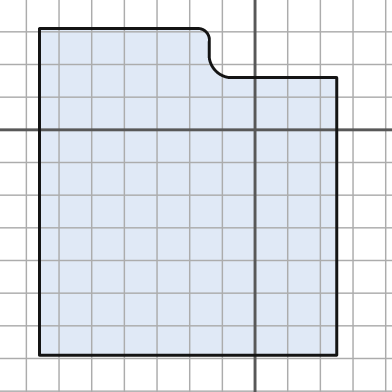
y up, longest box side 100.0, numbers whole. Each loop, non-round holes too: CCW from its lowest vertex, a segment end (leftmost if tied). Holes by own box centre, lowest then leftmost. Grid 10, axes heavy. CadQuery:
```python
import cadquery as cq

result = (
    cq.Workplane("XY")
    .moveTo(-66.0, -69.0)
    .lineTo(25.0, -69.0)
    .lineTo(25.0, 16.0)
    .lineTo(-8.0, 16.0)
    .threePointArc((-12.0, 18.0), (-14.0, 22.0))
    .lineTo(-14.0, 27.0)
    .threePointArc((-15.0, 30.0), (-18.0, 31.0))
    .lineTo(-66.0, 31.0)
    .close()
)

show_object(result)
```